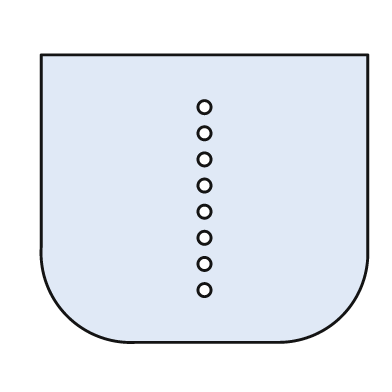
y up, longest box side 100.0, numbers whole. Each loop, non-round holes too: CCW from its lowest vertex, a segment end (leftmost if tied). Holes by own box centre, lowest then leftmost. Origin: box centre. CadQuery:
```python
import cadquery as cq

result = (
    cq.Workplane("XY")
    .moveTo(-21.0, -44.0)
    .lineTo(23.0, -44.0)
    .threePointArc((42.0, -36.0), (50.0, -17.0))
    .lineTo(50.0, 44.0)
    .lineTo(-50.0, 44.0)
    .lineTo(-50.0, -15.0)
    .threePointArc((-42.0, -36.0), (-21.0, -44.0))
    .close()
    .moveTo(0.0, -28.0)
    .circle(2.0)
    .moveTo(0.0, -20.0)
    .circle(2.0)
    .moveTo(0.0, -12.0)
    .circle(2.0)
    .moveTo(0.0, -4.0)
    .circle(2.0)
    .moveTo(0.0, 4.0)
    .circle(2.0)
    .moveTo(0.0, 12.0)
    .circle(2.0)
    .moveTo(0.0, 20.0)
    .circle(2.0)
    .moveTo(0.0, 28.0)
    .circle(2.0)
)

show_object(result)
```